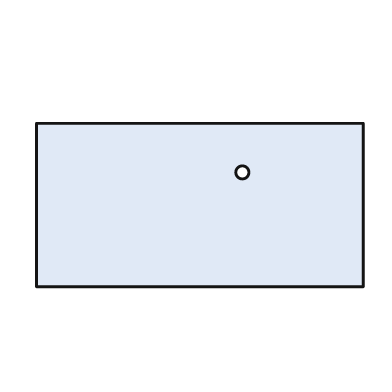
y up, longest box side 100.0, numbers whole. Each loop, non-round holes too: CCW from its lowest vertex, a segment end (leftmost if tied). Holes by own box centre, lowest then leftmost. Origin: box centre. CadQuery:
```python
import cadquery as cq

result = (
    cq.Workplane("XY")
    .moveTo(-50.0, -25.0)
    .lineTo(50.0, -25.0)
    .lineTo(50.0, 25.0)
    .lineTo(-50.0, 25.0)
    .close()
    .moveTo(13.0, 10.0)
    .circle(2.0)
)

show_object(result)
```